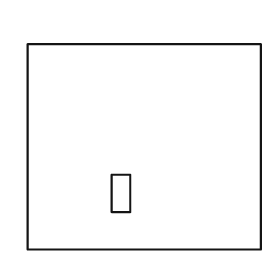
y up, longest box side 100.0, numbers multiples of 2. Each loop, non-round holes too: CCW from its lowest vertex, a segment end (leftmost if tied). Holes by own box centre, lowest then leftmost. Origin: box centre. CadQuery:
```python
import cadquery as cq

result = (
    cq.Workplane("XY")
    .moveTo(-50.0, -44.0)
    .lineTo(50.0, -44.0)
    .lineTo(50.0, 44.0)
    .lineTo(-50.0, 44.0)
    .close()
    .moveTo(-14.0, -28.0)
    .lineTo(-6.0, -28.0)
    .lineTo(-6.0, -12.0)
    .lineTo(-14.0, -12.0)
    .close()
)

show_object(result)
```